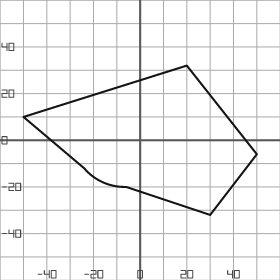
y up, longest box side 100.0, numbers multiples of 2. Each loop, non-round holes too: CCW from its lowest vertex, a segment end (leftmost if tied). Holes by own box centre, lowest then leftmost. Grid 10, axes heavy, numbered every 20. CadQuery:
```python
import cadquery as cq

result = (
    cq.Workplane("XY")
    .moveTo(30.0, -32.0)
    .lineTo(50.0, -6.0)
    .lineTo(20.0, 32.0)
    .lineTo(-50.0, 10.0)
    .lineTo(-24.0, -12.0)
    .threePointArc((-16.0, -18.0), (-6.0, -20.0))
    .close()
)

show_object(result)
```